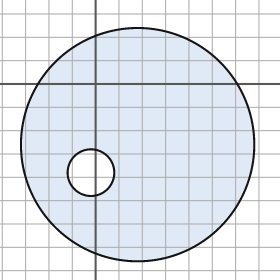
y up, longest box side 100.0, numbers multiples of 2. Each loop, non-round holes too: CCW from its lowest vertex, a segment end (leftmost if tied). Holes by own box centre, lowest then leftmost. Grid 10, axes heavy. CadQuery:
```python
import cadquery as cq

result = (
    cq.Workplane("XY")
    .moveTo(18.0, -26.0)
    .circle(50.0)
    .moveTo(-2.0, -38.0)
    .circle(10.0)
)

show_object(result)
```